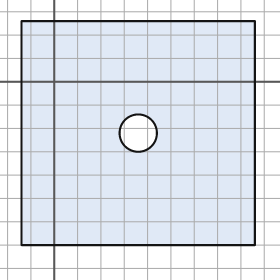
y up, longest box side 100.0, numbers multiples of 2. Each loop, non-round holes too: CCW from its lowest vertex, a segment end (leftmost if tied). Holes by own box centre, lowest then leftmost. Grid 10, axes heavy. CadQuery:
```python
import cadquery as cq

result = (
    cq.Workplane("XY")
    .moveTo(-14.0, -70.0)
    .lineTo(86.0, -70.0)
    .lineTo(86.0, 26.0)
    .lineTo(-14.0, 26.0)
    .close()
    .moveTo(36.0, -22.0)
    .circle(8.0)
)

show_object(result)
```